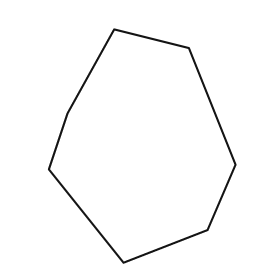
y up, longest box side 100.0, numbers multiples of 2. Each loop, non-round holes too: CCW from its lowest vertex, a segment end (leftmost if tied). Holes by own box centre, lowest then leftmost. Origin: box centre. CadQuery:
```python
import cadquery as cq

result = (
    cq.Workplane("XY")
    .moveTo(-8.0, -50.0)
    .lineTo(28.0, -36.0)
    .lineTo(40.0, -8.0)
    .lineTo(20.0, 42.0)
    .lineTo(-12.0, 50.0)
    .lineTo(-32.0, 14.0)
    .lineTo(-40.0, -10.0)
    .close()
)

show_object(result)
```